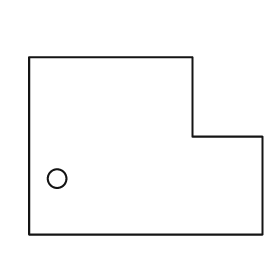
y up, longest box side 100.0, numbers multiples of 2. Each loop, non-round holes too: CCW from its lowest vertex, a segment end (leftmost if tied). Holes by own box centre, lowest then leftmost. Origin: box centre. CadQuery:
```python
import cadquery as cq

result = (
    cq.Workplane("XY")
    .moveTo(-50.0, -38.0)
    .lineTo(50.0, -38.0)
    .lineTo(50.0, 4.0)
    .lineTo(20.0, 4.0)
    .lineTo(20.0, 38.0)
    .lineTo(-50.0, 38.0)
    .close()
    .moveTo(-38.0, -14.0)
    .circle(4.0)
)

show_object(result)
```